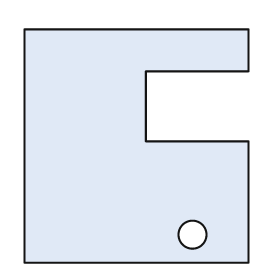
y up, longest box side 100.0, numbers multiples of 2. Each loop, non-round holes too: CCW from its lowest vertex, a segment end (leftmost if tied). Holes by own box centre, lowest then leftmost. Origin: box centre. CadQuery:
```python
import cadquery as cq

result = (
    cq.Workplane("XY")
    .moveTo(-48.0, -50.0)
    .lineTo(48.0, -50.0)
    .lineTo(48.0, 2.0)
    .lineTo(4.0, 2.0)
    .lineTo(4.0, 32.0)
    .lineTo(48.0, 32.0)
    .lineTo(48.0, 50.0)
    .lineTo(-48.0, 50.0)
    .close()
    .moveTo(24.0, -38.0)
    .circle(6.0)
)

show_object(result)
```